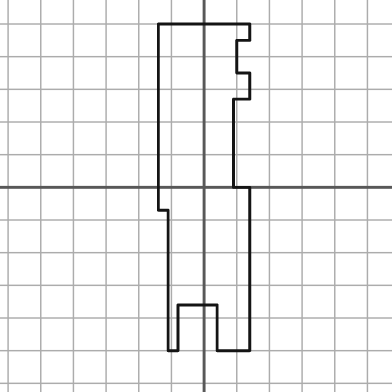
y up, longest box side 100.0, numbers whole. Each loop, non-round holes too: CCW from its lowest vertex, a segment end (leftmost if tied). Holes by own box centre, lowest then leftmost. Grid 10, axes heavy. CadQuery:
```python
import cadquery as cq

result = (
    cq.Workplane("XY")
    .moveTo(-11.0, -50.0)
    .lineTo(-8.0, -50.0)
    .lineTo(-8.0, -36.0)
    .lineTo(4.0, -36.0)
    .lineTo(4.0, -50.0)
    .lineTo(14.0, -50.0)
    .lineTo(14.0, 0.0)
    .lineTo(9.0, 0.0)
    .lineTo(9.0, 27.0)
    .lineTo(14.0, 27.0)
    .lineTo(14.0, 35.0)
    .lineTo(10.0, 35.0)
    .lineTo(10.0, 45.0)
    .lineTo(14.0, 45.0)
    .lineTo(14.0, 50.0)
    .lineTo(-14.0, 50.0)
    .lineTo(-14.0, -7.0)
    .lineTo(-11.0, -7.0)
    .close()
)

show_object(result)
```